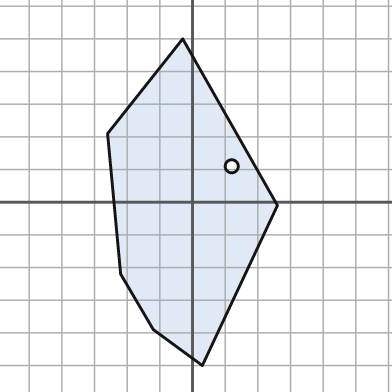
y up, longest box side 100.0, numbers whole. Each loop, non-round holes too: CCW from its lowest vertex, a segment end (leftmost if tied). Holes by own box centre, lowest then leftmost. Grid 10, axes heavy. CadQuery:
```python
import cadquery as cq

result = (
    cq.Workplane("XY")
    .moveTo(3.0, -50.0)
    .lineTo(26.0, -1.0)
    .lineTo(-3.0, 50.0)
    .lineTo(-26.0, 21.0)
    .lineTo(-22.0, -22.0)
    .lineTo(-12.0, -39.0)
    .close()
    .moveTo(12.0, 11.0)
    .circle(2.0)
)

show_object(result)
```